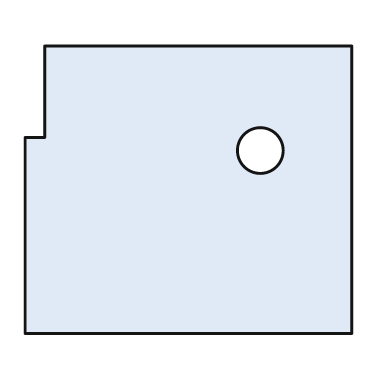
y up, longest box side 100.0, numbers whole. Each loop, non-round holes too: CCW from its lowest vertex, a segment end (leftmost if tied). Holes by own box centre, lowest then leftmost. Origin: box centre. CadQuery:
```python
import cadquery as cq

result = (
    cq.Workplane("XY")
    .moveTo(-50.0, -44.0)
    .lineTo(50.0, -44.0)
    .lineTo(50.0, 44.0)
    .lineTo(-44.0, 44.0)
    .lineTo(-44.0, 16.0)
    .lineTo(-50.0, 16.0)
    .close()
    .moveTo(22.0, 12.0)
    .circle(7.0)
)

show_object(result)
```